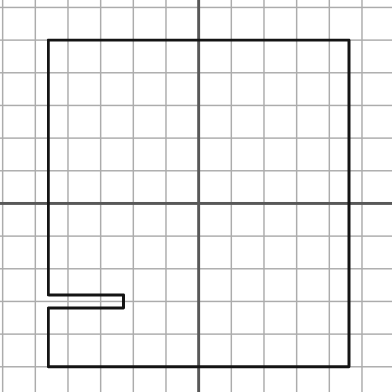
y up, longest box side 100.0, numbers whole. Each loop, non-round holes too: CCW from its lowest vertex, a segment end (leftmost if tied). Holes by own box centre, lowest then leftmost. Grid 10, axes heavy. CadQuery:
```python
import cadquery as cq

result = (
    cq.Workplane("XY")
    .moveTo(-46.0, -50.0)
    .lineTo(46.0, -50.0)
    .lineTo(46.0, 50.0)
    .lineTo(-46.0, 50.0)
    .lineTo(-46.0, -28.0)
    .lineTo(-23.0, -28.0)
    .lineTo(-23.0, -32.0)
    .lineTo(-46.0, -32.0)
    .close()
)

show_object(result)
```